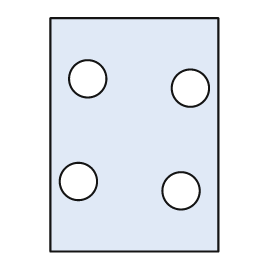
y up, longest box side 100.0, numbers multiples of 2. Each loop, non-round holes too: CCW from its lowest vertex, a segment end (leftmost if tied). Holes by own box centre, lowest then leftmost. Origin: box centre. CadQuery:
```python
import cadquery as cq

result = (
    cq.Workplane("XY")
    .moveTo(-36.0, -50.0)
    .lineTo(36.0, -50.0)
    .lineTo(36.0, 50.0)
    .lineTo(-36.0, 50.0)
    .close()
    .moveTo(20.0, -24.0)
    .circle(8.0)
    .moveTo(-24.0, -20.0)
    .circle(8.0)
    .moveTo(24.0, 20.0)
    .circle(8.0)
    .moveTo(-20.0, 24.0)
    .circle(8.0)
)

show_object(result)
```